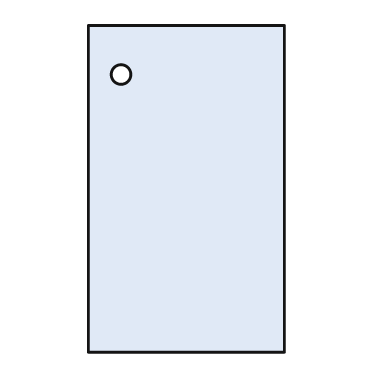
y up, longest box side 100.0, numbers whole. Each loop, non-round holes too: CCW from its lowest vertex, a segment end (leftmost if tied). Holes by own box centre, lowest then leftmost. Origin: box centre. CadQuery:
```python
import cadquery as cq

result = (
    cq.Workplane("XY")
    .moveTo(-30.0, -50.0)
    .lineTo(30.0, -50.0)
    .lineTo(30.0, 50.0)
    .lineTo(-30.0, 50.0)
    .close()
    .moveTo(-20.0, 35.0)
    .circle(3.0)
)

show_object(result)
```